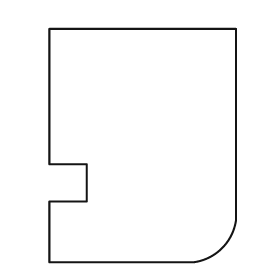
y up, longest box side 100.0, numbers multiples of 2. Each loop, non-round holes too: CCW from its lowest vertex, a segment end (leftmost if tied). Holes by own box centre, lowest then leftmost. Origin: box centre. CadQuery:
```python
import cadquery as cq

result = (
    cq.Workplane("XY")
    .moveTo(-40.0, -50.0)
    .lineTo(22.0, -50.0)
    .threePointArc((34.0, -44.0), (40.0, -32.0))
    .lineTo(40.0, 50.0)
    .lineTo(-40.0, 50.0)
    .lineTo(-40.0, -8.0)
    .lineTo(-24.0, -8.0)
    .lineTo(-24.0, -24.0)
    .lineTo(-40.0, -24.0)
    .close()
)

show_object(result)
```